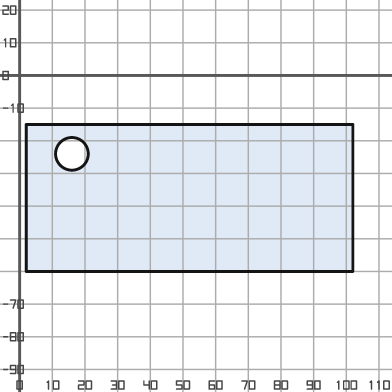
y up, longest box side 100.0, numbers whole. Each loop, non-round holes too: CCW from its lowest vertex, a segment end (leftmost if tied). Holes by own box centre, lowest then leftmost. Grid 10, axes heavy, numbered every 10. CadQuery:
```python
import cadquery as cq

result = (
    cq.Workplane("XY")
    .moveTo(2.0, -60.0)
    .lineTo(102.0, -60.0)
    .lineTo(102.0, -15.0)
    .lineTo(2.0, -15.0)
    .close()
    .moveTo(16.0, -24.0)
    .circle(5.0)
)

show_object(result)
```